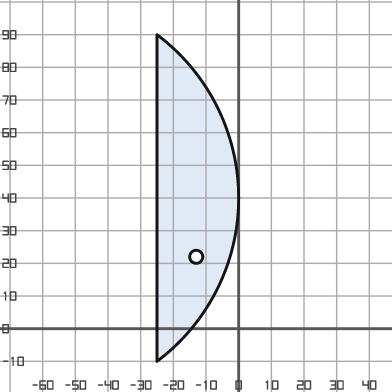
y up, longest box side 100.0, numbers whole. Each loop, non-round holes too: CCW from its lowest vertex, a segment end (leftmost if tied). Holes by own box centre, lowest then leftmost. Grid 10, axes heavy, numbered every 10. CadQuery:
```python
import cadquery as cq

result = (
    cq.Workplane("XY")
    .moveTo(-25.0, -10.0)
    .threePointArc((0.0, 40.0), (-25.0, 90.0))
    .close()
    .moveTo(-13.0, 22.0)
    .circle(2.0)
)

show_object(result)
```